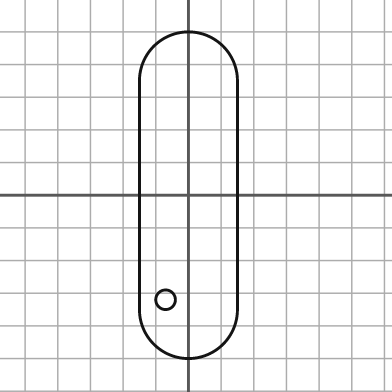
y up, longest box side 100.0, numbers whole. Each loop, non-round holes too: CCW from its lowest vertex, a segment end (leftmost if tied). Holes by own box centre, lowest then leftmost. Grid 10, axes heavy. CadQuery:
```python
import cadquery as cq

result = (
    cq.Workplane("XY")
    .moveTo(-15.0, -35.0)
    .threePointArc((0.0, -50.0), (15.0, -35.0))
    .lineTo(15.0, 35.0)
    .threePointArc((0.0, 50.0), (-15.0, 35.0))
    .close()
    .moveTo(-7.0, -32.0)
    .circle(3.0)
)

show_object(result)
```